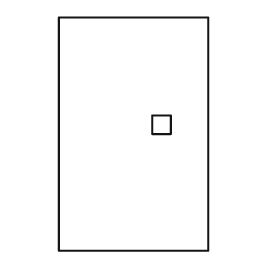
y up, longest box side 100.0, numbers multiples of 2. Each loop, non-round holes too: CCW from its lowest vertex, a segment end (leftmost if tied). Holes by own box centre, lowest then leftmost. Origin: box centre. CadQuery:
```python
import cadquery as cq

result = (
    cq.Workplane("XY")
    .moveTo(-32.0, -50.0)
    .lineTo(32.0, -50.0)
    .lineTo(32.0, 50.0)
    .lineTo(-32.0, 50.0)
    .close()
    .moveTo(8.0, 0.0)
    .lineTo(16.0, 0.0)
    .lineTo(16.0, 8.0)
    .lineTo(8.0, 8.0)
    .close()
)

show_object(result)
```